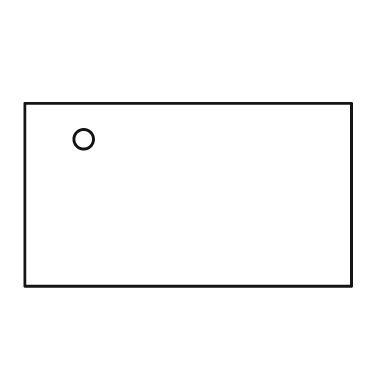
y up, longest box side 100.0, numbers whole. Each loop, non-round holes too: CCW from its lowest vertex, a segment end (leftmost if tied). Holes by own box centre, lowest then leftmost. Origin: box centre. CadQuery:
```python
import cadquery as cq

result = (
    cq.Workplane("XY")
    .moveTo(-50.0, -28.0)
    .lineTo(50.0, -28.0)
    .lineTo(50.0, 28.0)
    .lineTo(-50.0, 28.0)
    .close()
    .moveTo(-32.0, 17.0)
    .circle(3.0)
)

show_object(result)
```